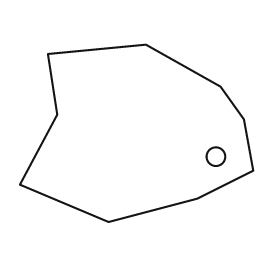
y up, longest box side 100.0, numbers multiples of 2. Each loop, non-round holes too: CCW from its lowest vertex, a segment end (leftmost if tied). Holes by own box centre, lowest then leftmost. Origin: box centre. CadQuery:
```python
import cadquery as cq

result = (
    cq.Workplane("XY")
    .moveTo(-12.0, -38.0)
    .lineTo(26.0, -28.0)
    .lineTo(50.0, -16.0)
    .lineTo(46.0, 6.0)
    .lineTo(36.0, 20.0)
    .lineTo(4.0, 38.0)
    .lineTo(-38.0, 34.0)
    .lineTo(-34.0, 8.0)
    .lineTo(-50.0, -22.0)
    .close()
    .moveTo(34.0, -10.0)
    .circle(4.0)
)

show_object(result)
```